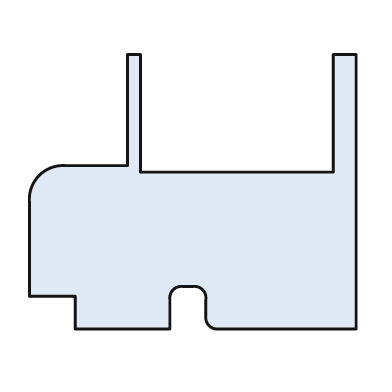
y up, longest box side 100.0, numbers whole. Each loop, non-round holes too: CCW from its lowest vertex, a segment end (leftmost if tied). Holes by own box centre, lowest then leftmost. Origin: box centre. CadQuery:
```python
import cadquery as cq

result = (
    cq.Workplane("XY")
    .moveTo(-36.0, -42.0)
    .lineTo(-7.0, -42.0)
    .lineTo(-7.0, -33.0)
    .threePointArc((-6.0, -30.0), (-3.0, -29.0))
    .lineTo(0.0, -29.0)
    .threePointArc((3.0, -30.0), (4.0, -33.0))
    .lineTo(4.0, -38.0)
    .threePointArc((5.0, -41.0), (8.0, -42.0))
    .lineTo(50.0, -42.0)
    .lineTo(50.0, 42.0)
    .lineTo(43.0, 42.0)
    .lineTo(43.0, 6.0)
    .lineTo(-16.0, 6.0)
    .lineTo(-16.0, 42.0)
    .lineTo(-20.0, 42.0)
    .lineTo(-20.0, 8.0)
    .lineTo(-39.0, 8.0)
    .threePointArc((-47.0, 5.0), (-50.0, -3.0))
    .lineTo(-50.0, -32.0)
    .lineTo(-36.0, -32.0)
    .close()
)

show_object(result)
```